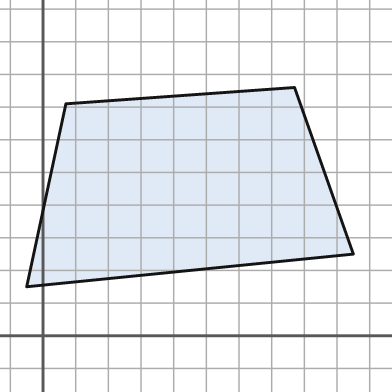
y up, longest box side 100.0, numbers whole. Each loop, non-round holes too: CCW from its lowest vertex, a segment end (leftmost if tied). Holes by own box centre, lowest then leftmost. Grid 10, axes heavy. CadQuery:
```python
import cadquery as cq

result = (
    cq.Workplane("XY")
    .moveTo(-5.0, 15.0)
    .lineTo(95.0, 25.0)
    .lineTo(77.0, 76.0)
    .lineTo(7.0, 71.0)
    .close()
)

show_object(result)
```